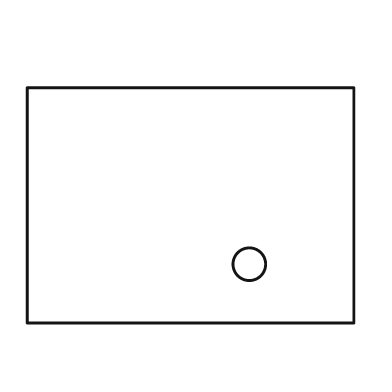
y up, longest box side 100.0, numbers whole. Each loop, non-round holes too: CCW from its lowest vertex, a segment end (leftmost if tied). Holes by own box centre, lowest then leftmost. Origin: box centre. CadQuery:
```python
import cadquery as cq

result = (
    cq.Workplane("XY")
    .moveTo(-50.0, -36.0)
    .lineTo(50.0, -36.0)
    .lineTo(50.0, 36.0)
    .lineTo(-50.0, 36.0)
    .close()
    .moveTo(18.0, -18.0)
    .circle(5.0)
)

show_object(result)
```